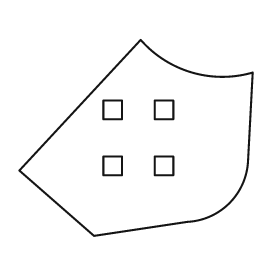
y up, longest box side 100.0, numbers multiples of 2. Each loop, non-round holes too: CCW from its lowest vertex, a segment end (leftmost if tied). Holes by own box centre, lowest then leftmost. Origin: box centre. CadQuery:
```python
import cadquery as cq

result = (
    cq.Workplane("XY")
    .moveTo(-18.0, -42.0)
    .lineTo(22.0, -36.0)
    .threePointArc((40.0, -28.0), (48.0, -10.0))
    .lineTo(50.0, 28.0)
    .threePointArc((24.0, 28.0), (2.0, 42.0))
    .lineTo(-50.0, -14.0)
    .close()
    .moveTo(-14.0, -16.0)
    .lineTo(-6.0, -16.0)
    .lineTo(-6.0, -8.0)
    .lineTo(-14.0, -8.0)
    .close()
    .moveTo(8.0, -16.0)
    .lineTo(16.0, -16.0)
    .lineTo(16.0, -8.0)
    .lineTo(8.0, -8.0)
    .close()
    .moveTo(-14.0, 8.0)
    .lineTo(-6.0, 8.0)
    .lineTo(-6.0, 16.0)
    .lineTo(-14.0, 16.0)
    .close()
    .moveTo(8.0, 8.0)
    .lineTo(16.0, 8.0)
    .lineTo(16.0, 16.0)
    .lineTo(8.0, 16.0)
    .close()
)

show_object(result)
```